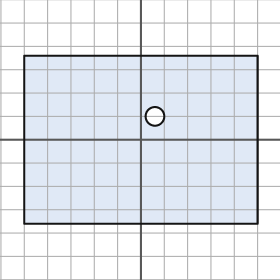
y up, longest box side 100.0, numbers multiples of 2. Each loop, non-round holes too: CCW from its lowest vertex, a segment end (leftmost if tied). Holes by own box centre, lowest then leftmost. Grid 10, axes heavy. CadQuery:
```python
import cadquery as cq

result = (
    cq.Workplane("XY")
    .moveTo(-50.0, -36.0)
    .lineTo(50.0, -36.0)
    .lineTo(50.0, 36.0)
    .lineTo(-50.0, 36.0)
    .close()
    .moveTo(6.0, 10.0)
    .circle(4.0)
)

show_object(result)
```